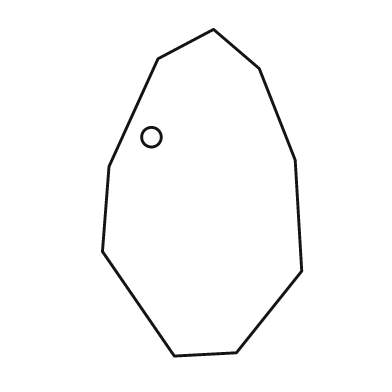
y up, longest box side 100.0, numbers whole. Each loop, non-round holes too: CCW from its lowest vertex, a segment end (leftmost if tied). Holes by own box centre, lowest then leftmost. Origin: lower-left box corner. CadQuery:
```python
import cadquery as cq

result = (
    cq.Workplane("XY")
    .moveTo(22.0, 0.0)
    .lineTo(41.0, 1.0)
    .lineTo(61.0, 26.0)
    .lineTo(59.0, 60.0)
    .lineTo(48.0, 88.0)
    .lineTo(34.0, 100.0)
    .lineTo(17.0, 91.0)
    .lineTo(2.0, 58.0)
    .lineTo(0.0, 32.0)
    .close()
    .moveTo(15.0, 67.0)
    .circle(3.0)
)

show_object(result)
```